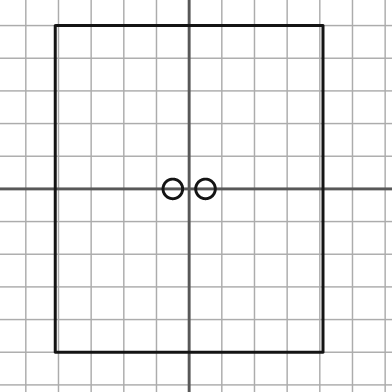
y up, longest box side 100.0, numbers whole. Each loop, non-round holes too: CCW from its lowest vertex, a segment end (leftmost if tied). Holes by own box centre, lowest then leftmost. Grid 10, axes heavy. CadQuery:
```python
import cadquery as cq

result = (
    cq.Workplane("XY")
    .moveTo(-41.0, -50.0)
    .lineTo(41.0, -50.0)
    .lineTo(41.0, 50.0)
    .lineTo(-41.0, 50.0)
    .close()
    .moveTo(-5.0, 0.0)
    .circle(3.0)
    .moveTo(5.0, 0.0)
    .circle(3.0)
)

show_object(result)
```